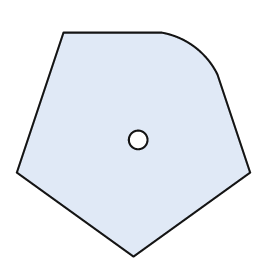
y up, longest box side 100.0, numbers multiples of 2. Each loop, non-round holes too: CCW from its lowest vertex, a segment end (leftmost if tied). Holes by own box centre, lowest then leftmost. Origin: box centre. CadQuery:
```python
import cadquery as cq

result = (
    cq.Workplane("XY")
    .moveTo(0.0, -48.0)
    .lineTo(50.0, -12.0)
    .lineTo(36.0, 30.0)
    .threePointArc((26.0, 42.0), (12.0, 48.0))
    .lineTo(-30.0, 48.0)
    .lineTo(-50.0, -12.0)
    .close()
    .moveTo(2.0, 2.0)
    .circle(4.0)
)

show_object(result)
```